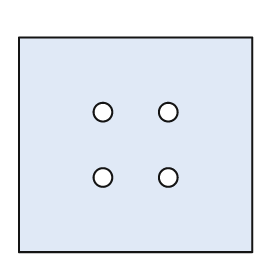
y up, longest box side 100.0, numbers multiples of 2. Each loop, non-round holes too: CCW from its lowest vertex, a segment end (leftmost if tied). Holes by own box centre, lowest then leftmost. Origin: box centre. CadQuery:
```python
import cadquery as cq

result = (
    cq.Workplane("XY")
    .moveTo(-50.0, -46.0)
    .lineTo(50.0, -46.0)
    .lineTo(50.0, 46.0)
    .lineTo(-50.0, 46.0)
    .close()
    .moveTo(-14.0, -14.0)
    .circle(4.0)
    .moveTo(14.0, -14.0)
    .circle(4.0)
    .moveTo(-14.0, 14.0)
    .circle(4.0)
    .moveTo(14.0, 14.0)
    .circle(4.0)
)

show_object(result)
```